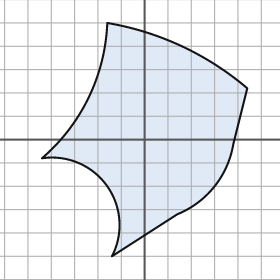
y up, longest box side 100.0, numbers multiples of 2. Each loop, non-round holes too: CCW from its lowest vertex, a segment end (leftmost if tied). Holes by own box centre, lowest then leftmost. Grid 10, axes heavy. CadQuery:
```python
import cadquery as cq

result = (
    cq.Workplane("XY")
    .moveTo(-14.0, -50.0)
    .lineTo(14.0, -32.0)
    .threePointArc((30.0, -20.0), (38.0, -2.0))
    .lineTo(44.0, 22.0)
    .threePointArc((16.0, 40.0), (-16.0, 50.0))
    .threePointArc((-24.0, 18.0), (-44.0, -8.0))
    .threePointArc((-16.0, -20.0), (-14.0, -50.0))
    .close()
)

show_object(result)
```